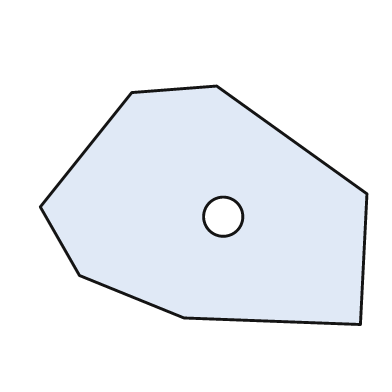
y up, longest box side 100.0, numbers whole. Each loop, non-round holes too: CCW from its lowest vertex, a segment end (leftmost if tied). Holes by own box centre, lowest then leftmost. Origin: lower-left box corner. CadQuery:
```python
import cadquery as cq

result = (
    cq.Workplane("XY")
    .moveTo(98.0, 0.0)
    .lineTo(100.0, 40.0)
    .lineTo(54.0, 73.0)
    .lineTo(28.0, 71.0)
    .lineTo(0.0, 36.0)
    .lineTo(12.0, 15.0)
    .lineTo(44.0, 2.0)
    .close()
    .moveTo(56.0, 33.0)
    .circle(6.0)
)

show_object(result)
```